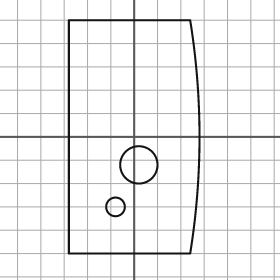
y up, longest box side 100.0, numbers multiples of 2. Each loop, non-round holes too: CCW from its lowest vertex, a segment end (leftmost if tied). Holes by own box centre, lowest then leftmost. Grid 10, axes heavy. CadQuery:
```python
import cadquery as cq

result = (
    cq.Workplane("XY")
    .moveTo(-28.0, -50.0)
    .lineTo(24.0, -50.0)
    .threePointArc((28.0, 0.0), (24.0, 50.0))
    .lineTo(-28.0, 50.0)
    .close()
    .moveTo(-8.0, -30.0)
    .circle(4.0)
    .moveTo(2.0, -12.0)
    .circle(8.0)
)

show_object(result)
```